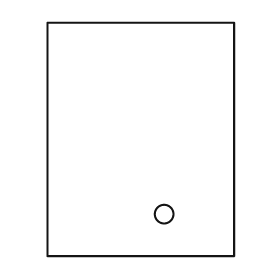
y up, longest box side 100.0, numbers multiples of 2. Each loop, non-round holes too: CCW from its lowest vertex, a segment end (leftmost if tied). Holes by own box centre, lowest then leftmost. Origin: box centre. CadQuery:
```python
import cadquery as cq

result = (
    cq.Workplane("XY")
    .moveTo(-40.0, -50.0)
    .lineTo(40.0, -50.0)
    .lineTo(40.0, 50.0)
    .lineTo(-40.0, 50.0)
    .close()
    .moveTo(10.0, -32.0)
    .circle(4.0)
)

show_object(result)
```